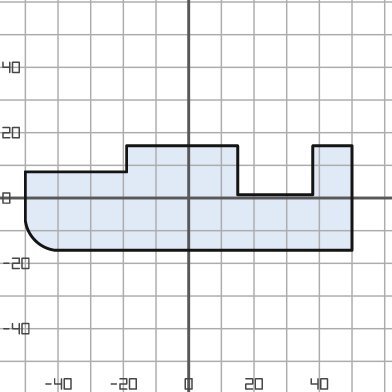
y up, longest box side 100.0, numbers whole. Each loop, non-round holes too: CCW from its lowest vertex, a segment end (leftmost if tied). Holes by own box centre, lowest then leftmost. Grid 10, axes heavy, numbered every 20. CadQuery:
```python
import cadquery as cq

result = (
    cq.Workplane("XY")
    .moveTo(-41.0, -16.0)
    .lineTo(50.0, -16.0)
    .lineTo(50.0, 16.0)
    .lineTo(38.0, 16.0)
    .lineTo(38.0, 1.0)
    .lineTo(15.0, 1.0)
    .lineTo(15.0, 16.0)
    .lineTo(-19.0, 16.0)
    .lineTo(-19.0, 8.0)
    .lineTo(-50.0, 8.0)
    .lineTo(-50.0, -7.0)
    .threePointArc((-47.0, -13.0), (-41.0, -16.0))
    .close()
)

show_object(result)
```